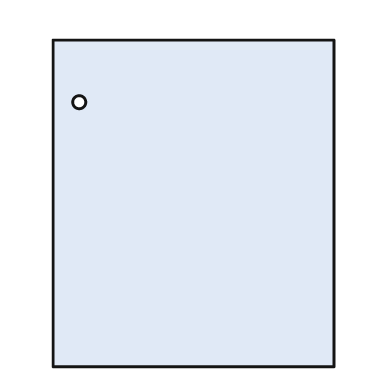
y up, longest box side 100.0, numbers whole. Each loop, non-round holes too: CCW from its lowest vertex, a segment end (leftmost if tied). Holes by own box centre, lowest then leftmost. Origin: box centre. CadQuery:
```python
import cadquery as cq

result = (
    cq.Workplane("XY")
    .moveTo(-43.0, -50.0)
    .lineTo(43.0, -50.0)
    .lineTo(43.0, 50.0)
    .lineTo(-43.0, 50.0)
    .close()
    .moveTo(-35.0, 31.0)
    .circle(2.0)
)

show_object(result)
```